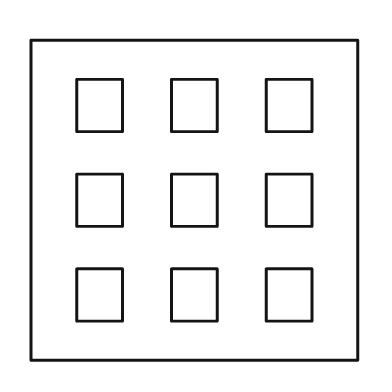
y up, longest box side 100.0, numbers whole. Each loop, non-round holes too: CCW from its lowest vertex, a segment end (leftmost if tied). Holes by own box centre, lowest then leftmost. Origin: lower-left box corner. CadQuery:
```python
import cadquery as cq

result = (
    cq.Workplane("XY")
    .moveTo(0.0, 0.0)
    .lineTo(100.0, 0.0)
    .lineTo(100.0, 98.0)
    .lineTo(0.0, 98.0)
    .close()
    .moveTo(14.0, 12.0)
    .lineTo(28.0, 12.0)
    .lineTo(28.0, 28.0)
    .lineTo(14.0, 28.0)
    .close()
    .moveTo(43.0, 12.0)
    .lineTo(57.0, 12.0)
    .lineTo(57.0, 28.0)
    .lineTo(43.0, 28.0)
    .close()
    .moveTo(72.0, 12.0)
    .lineTo(86.0, 12.0)
    .lineTo(86.0, 28.0)
    .lineTo(72.0, 28.0)
    .close()
    .moveTo(14.0, 41.0)
    .lineTo(28.0, 41.0)
    .lineTo(28.0, 57.0)
    .lineTo(14.0, 57.0)
    .close()
    .moveTo(43.0, 41.0)
    .lineTo(57.0, 41.0)
    .lineTo(57.0, 57.0)
    .lineTo(43.0, 57.0)
    .close()
    .moveTo(72.0, 41.0)
    .lineTo(86.0, 41.0)
    .lineTo(86.0, 57.0)
    .lineTo(72.0, 57.0)
    .close()
    .moveTo(14.0, 70.0)
    .lineTo(28.0, 70.0)
    .lineTo(28.0, 86.0)
    .lineTo(14.0, 86.0)
    .close()
    .moveTo(43.0, 70.0)
    .lineTo(57.0, 70.0)
    .lineTo(57.0, 86.0)
    .lineTo(43.0, 86.0)
    .close()
    .moveTo(72.0, 70.0)
    .lineTo(86.0, 70.0)
    .lineTo(86.0, 86.0)
    .lineTo(72.0, 86.0)
    .close()
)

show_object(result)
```